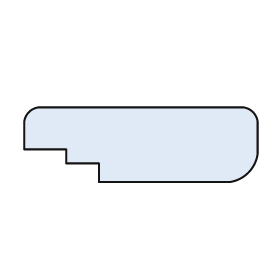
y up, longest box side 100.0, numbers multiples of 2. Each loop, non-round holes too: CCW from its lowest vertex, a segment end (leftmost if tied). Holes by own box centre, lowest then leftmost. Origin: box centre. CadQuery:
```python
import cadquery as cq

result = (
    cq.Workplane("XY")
    .moveTo(-18.0, -16.0)
    .lineTo(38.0, -16.0)
    .threePointArc((46.0, -12.0), (50.0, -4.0))
    .lineTo(50.0, 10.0)
    .threePointArc((48.0, 14.0), (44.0, 16.0))
    .lineTo(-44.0, 16.0)
    .threePointArc((-48.0, 14.0), (-50.0, 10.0))
    .lineTo(-50.0, -2.0)
    .lineTo(-32.0, -2.0)
    .lineTo(-32.0, -8.0)
    .lineTo(-18.0, -8.0)
    .close()
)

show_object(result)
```